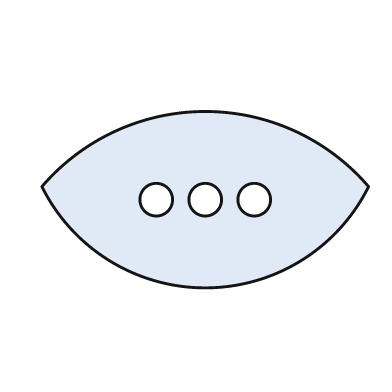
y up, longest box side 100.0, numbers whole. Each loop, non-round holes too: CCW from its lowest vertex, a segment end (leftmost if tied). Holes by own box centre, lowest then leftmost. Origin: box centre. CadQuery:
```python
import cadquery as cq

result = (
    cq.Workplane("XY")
    .moveTo(-50.0, 4.0)
    .threePointArc((0.0, -27.0), (50.0, 4.0))
    .threePointArc((0.0, 27.0), (-50.0, 4.0))
    .close()
    .moveTo(-15.0, 0.0)
    .circle(5.0)
    .moveTo(0.0, 0.0)
    .circle(5.0)
    .moveTo(15.0, 0.0)
    .circle(5.0)
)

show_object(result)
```